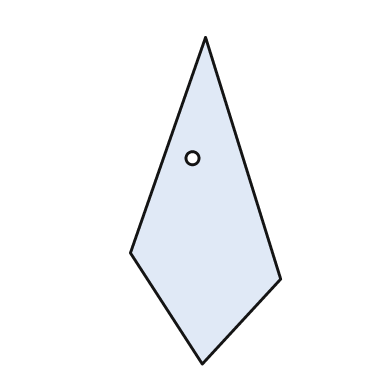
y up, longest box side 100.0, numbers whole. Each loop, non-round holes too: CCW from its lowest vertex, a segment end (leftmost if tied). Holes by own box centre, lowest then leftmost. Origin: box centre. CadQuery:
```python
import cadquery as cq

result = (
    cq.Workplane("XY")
    .moveTo(-1.0, -50.0)
    .lineTo(23.0, -24.0)
    .lineTo(0.0, 50.0)
    .lineTo(-23.0, -16.0)
    .close()
    .moveTo(-4.0, 13.0)
    .circle(2.0)
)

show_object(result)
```